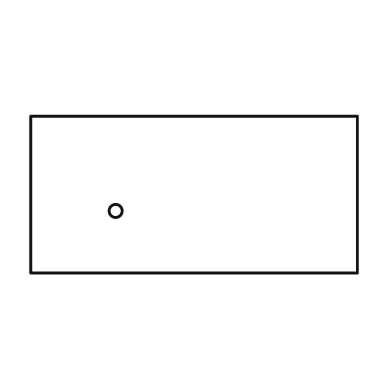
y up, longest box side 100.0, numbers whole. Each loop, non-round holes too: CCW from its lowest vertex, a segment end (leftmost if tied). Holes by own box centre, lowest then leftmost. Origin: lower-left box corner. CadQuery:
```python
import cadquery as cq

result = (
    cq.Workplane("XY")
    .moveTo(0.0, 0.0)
    .lineTo(100.0, 0.0)
    .lineTo(100.0, 48.0)
    .lineTo(0.0, 48.0)
    .close()
    .moveTo(26.0, 19.0)
    .circle(2.0)
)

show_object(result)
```